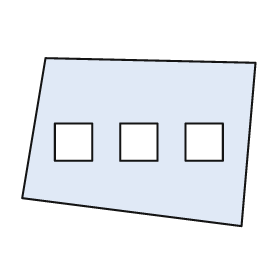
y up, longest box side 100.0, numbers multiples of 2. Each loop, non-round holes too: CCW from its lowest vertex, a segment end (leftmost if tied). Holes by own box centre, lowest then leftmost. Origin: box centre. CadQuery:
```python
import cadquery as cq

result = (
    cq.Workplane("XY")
    .moveTo(44.0, -36.0)
    .lineTo(50.0, 34.0)
    .lineTo(-40.0, 36.0)
    .lineTo(-50.0, -24.0)
    .close()
    .moveTo(-36.0, -8.0)
    .lineTo(-20.0, -8.0)
    .lineTo(-20.0, 8.0)
    .lineTo(-36.0, 8.0)
    .close()
    .moveTo(-8.0, -8.0)
    .lineTo(8.0, -8.0)
    .lineTo(8.0, 8.0)
    .lineTo(-8.0, 8.0)
    .close()
    .moveTo(20.0, -8.0)
    .lineTo(36.0, -8.0)
    .lineTo(36.0, 8.0)
    .lineTo(20.0, 8.0)
    .close()
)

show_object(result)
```